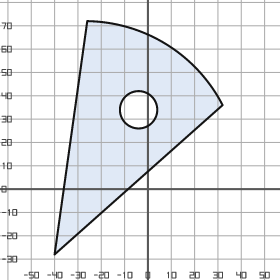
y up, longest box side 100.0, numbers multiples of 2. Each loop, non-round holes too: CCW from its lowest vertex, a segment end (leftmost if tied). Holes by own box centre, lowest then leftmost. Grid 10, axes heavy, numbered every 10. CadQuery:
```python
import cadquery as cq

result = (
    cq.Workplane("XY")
    .moveTo(-40.0, -28.0)
    .lineTo(32.0, 36.0)
    .threePointArc((8.0, 62.0), (-26.0, 72.0))
    .close()
    .moveTo(-4.0, 34.0)
    .circle(8.0)
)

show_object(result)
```